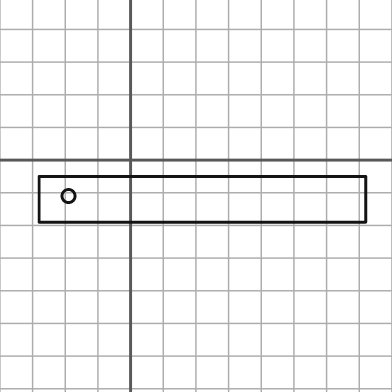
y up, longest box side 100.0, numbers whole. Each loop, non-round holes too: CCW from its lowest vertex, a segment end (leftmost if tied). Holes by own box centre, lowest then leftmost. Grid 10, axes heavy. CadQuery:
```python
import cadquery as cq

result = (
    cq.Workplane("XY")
    .moveTo(-28.0, -19.0)
    .lineTo(72.0, -19.0)
    .lineTo(72.0, -5.0)
    .lineTo(-28.0, -5.0)
    .close()
    .moveTo(-19.0, -11.0)
    .circle(2.0)
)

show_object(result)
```